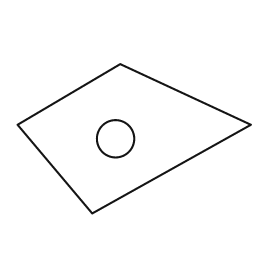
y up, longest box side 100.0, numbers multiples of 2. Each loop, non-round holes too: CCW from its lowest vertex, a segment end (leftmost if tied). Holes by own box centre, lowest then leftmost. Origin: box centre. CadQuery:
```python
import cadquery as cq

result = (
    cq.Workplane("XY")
    .moveTo(-18.0, -32.0)
    .lineTo(50.0, 6.0)
    .lineTo(-6.0, 32.0)
    .lineTo(-50.0, 6.0)
    .close()
    .moveTo(-8.0, 0.0)
    .circle(8.0)
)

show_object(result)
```